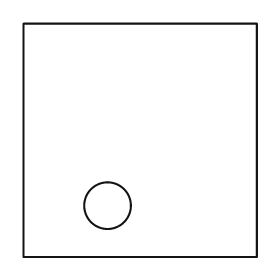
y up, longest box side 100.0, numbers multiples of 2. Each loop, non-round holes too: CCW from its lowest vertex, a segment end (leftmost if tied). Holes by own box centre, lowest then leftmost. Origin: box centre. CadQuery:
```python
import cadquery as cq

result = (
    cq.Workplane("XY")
    .moveTo(-50.0, -50.0)
    .lineTo(50.0, -50.0)
    .lineTo(50.0, 50.0)
    .lineTo(-50.0, 50.0)
    .close()
    .moveTo(-14.0, -28.0)
    .circle(10.0)
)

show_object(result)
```